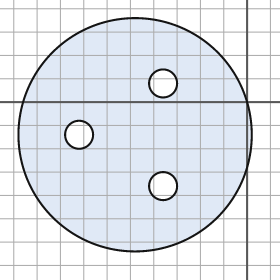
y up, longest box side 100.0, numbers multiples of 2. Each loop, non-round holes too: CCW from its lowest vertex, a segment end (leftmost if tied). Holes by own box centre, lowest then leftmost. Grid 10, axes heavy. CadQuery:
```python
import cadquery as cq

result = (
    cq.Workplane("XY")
    .moveTo(-48.0, -14.0)
    .circle(50.0)
    .moveTo(-36.0, -36.0)
    .circle(6.0)
    .moveTo(-72.0, -14.0)
    .circle(6.0)
    .moveTo(-36.0, 8.0)
    .circle(6.0)
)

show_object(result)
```